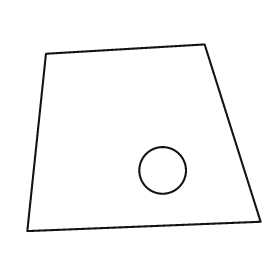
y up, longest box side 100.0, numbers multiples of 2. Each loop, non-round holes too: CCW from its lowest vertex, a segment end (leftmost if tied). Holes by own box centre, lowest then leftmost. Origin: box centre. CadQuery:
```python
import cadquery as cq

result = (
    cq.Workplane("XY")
    .moveTo(-50.0, -40.0)
    .lineTo(50.0, -36.0)
    .lineTo(26.0, 40.0)
    .lineTo(-42.0, 36.0)
    .close()
    .moveTo(8.0, -14.0)
    .circle(10.0)
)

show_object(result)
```